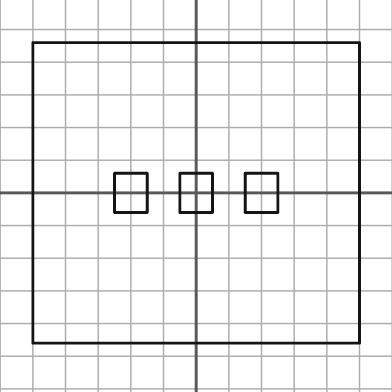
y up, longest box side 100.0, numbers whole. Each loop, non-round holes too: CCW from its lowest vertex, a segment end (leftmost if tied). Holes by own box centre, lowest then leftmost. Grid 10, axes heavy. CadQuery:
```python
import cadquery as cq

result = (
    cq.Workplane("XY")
    .moveTo(-50.0, -46.0)
    .lineTo(50.0, -46.0)
    .lineTo(50.0, 46.0)
    .lineTo(-50.0, 46.0)
    .close()
    .moveTo(-25.0, -6.0)
    .lineTo(-15.0, -6.0)
    .lineTo(-15.0, 6.0)
    .lineTo(-25.0, 6.0)
    .close()
    .moveTo(-5.0, -6.0)
    .lineTo(5.0, -6.0)
    .lineTo(5.0, 6.0)
    .lineTo(-5.0, 6.0)
    .close()
    .moveTo(15.0, -6.0)
    .lineTo(25.0, -6.0)
    .lineTo(25.0, 6.0)
    .lineTo(15.0, 6.0)
    .close()
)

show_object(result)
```